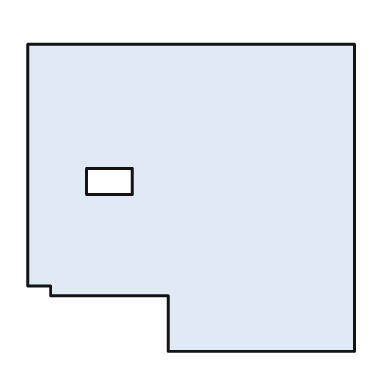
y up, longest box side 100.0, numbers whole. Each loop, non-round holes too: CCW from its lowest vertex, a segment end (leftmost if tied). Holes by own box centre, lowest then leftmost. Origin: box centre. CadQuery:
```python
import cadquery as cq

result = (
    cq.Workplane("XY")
    .moveTo(-7.0, -47.0)
    .lineTo(50.0, -47.0)
    .lineTo(50.0, 47.0)
    .lineTo(-50.0, 47.0)
    .lineTo(-50.0, -27.0)
    .lineTo(-43.0, -27.0)
    .lineTo(-43.0, -30.0)
    .lineTo(-7.0, -30.0)
    .close()
    .moveTo(-32.0, 1.0)
    .lineTo(-18.0, 1.0)
    .lineTo(-18.0, 9.0)
    .lineTo(-32.0, 9.0)
    .close()
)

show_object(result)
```